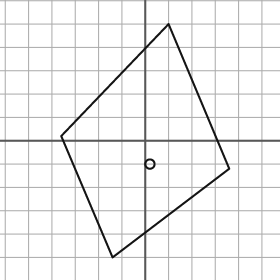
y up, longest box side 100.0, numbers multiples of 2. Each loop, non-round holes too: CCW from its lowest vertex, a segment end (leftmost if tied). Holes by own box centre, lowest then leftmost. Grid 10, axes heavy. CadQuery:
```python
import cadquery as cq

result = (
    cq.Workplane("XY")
    .moveTo(-14.0, -50.0)
    .lineTo(36.0, -12.0)
    .lineTo(10.0, 50.0)
    .lineTo(-36.0, 2.0)
    .close()
    .moveTo(2.0, -10.0)
    .circle(2.0)
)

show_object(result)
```